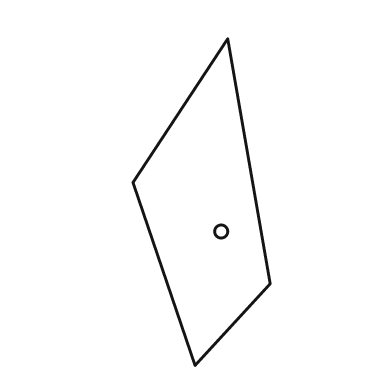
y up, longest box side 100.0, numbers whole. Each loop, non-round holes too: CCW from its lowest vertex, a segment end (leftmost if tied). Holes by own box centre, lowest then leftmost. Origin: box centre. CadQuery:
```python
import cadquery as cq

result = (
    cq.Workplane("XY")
    .moveTo(-2.0, -50.0)
    .lineTo(21.0, -25.0)
    .lineTo(8.0, 50.0)
    .lineTo(-21.0, 6.0)
    .close()
    .moveTo(6.0, -9.0)
    .circle(2.0)
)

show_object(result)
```